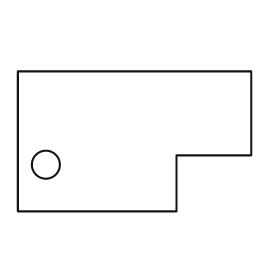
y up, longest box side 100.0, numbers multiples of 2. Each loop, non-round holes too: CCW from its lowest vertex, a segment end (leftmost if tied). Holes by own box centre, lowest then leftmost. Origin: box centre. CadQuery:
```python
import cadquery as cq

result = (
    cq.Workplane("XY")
    .moveTo(-50.0, -30.0)
    .lineTo(18.0, -30.0)
    .lineTo(18.0, -6.0)
    .lineTo(50.0, -6.0)
    .lineTo(50.0, 30.0)
    .lineTo(-50.0, 30.0)
    .close()
    .moveTo(-38.0, -10.0)
    .circle(6.0)
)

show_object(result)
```